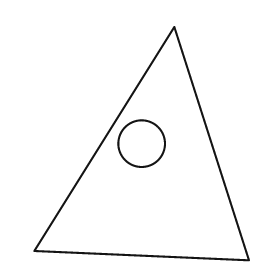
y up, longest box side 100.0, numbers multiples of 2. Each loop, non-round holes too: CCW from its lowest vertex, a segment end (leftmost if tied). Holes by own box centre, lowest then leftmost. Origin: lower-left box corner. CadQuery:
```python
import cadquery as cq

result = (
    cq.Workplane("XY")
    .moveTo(92.0, 0.0)
    .lineTo(60.0, 100.0)
    .lineTo(0.0, 4.0)
    .close()
    .moveTo(46.0, 50.0)
    .circle(10.0)
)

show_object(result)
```